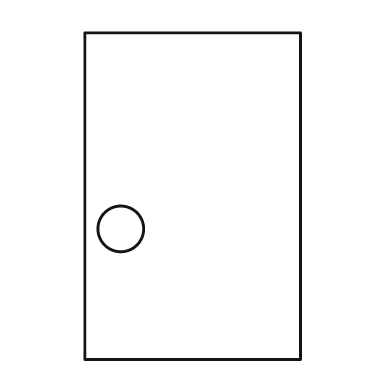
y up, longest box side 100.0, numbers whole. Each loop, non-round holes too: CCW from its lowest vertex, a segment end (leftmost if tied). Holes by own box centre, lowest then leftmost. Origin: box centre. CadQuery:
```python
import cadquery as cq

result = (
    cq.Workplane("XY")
    .moveTo(-33.0, -50.0)
    .lineTo(33.0, -50.0)
    .lineTo(33.0, 50.0)
    .lineTo(-33.0, 50.0)
    .close()
    .moveTo(-22.0, -10.0)
    .circle(7.0)
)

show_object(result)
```